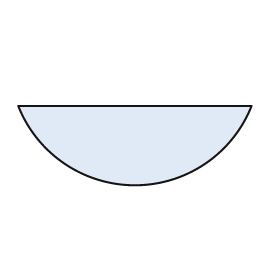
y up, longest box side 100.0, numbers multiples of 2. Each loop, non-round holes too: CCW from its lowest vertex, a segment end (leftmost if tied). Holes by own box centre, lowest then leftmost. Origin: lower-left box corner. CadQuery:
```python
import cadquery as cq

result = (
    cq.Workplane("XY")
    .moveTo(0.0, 34.0)
    .threePointArc((50.0, 0.0), (100.0, 34.0))
    .close()
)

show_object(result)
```